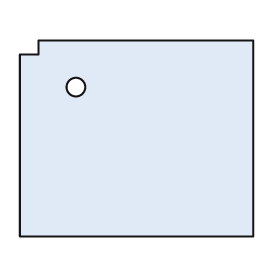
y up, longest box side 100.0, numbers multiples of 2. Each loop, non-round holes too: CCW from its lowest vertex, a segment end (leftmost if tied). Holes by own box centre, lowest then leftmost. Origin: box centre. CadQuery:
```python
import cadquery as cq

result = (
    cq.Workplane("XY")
    .moveTo(-50.0, -42.0)
    .lineTo(50.0, -42.0)
    .lineTo(50.0, 42.0)
    .lineTo(-42.0, 42.0)
    .lineTo(-42.0, 36.0)
    .lineTo(-50.0, 36.0)
    .close()
    .moveTo(-26.0, 22.0)
    .circle(4.0)
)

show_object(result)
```